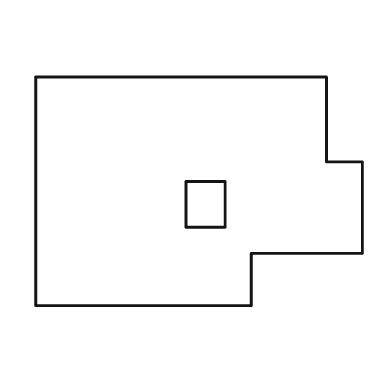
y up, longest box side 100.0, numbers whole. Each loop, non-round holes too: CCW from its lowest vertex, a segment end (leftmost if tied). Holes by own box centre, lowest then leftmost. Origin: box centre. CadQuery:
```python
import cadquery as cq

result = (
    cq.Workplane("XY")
    .moveTo(-50.0, -35.0)
    .lineTo(16.0, -35.0)
    .lineTo(16.0, -19.0)
    .lineTo(50.0, -19.0)
    .lineTo(50.0, 9.0)
    .lineTo(39.0, 9.0)
    .lineTo(39.0, 35.0)
    .lineTo(-50.0, 35.0)
    .close()
    .moveTo(-4.0, -11.0)
    .lineTo(8.0, -11.0)
    .lineTo(8.0, 3.0)
    .lineTo(-4.0, 3.0)
    .close()
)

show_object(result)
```